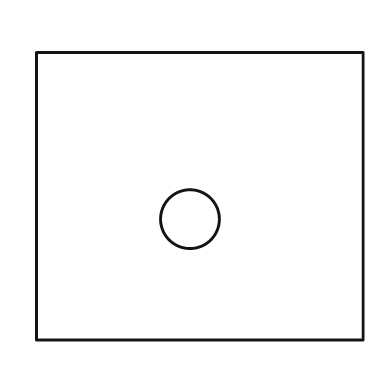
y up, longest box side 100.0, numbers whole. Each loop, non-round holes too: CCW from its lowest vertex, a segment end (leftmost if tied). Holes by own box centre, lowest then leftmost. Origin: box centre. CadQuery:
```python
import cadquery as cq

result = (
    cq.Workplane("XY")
    .moveTo(-50.0, -44.0)
    .lineTo(50.0, -44.0)
    .lineTo(50.0, 44.0)
    .lineTo(-50.0, 44.0)
    .close()
    .moveTo(-3.0, -7.0)
    .circle(9.0)
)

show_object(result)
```